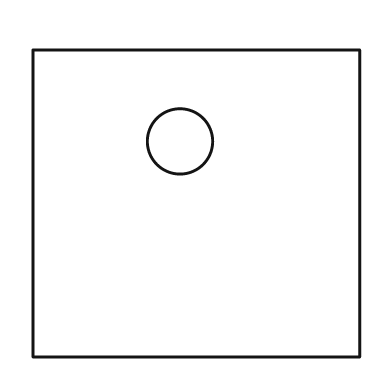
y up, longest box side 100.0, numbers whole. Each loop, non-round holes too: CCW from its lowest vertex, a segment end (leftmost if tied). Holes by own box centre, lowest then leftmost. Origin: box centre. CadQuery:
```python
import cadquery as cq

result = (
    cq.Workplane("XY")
    .moveTo(-50.0, -47.0)
    .lineTo(50.0, -47.0)
    .lineTo(50.0, 47.0)
    .lineTo(-50.0, 47.0)
    .close()
    .moveTo(-5.0, 19.0)
    .circle(10.0)
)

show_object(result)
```